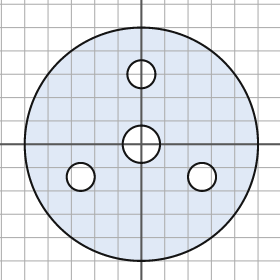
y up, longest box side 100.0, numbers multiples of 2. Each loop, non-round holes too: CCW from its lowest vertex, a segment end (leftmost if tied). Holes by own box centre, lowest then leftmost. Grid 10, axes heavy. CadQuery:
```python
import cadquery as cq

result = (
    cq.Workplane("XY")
    .moveTo(0.0, 0.0)
    .circle(50.0)
    .moveTo(-26.0, -14.0)
    .circle(6.0)
    .moveTo(26.0, -14.0)
    .circle(6.0)
    .moveTo(0.0, 0.0)
    .circle(8.0)
    .moveTo(0.0, 30.0)
    .circle(6.0)
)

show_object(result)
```